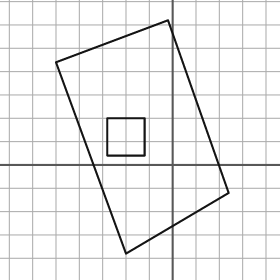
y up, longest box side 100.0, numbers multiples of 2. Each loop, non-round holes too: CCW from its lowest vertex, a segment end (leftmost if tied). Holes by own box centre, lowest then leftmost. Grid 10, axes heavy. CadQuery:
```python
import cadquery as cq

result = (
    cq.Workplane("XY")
    .moveTo(-20.0, -38.0)
    .lineTo(24.0, -12.0)
    .lineTo(-2.0, 62.0)
    .lineTo(-50.0, 44.0)
    .close()
    .moveTo(-28.0, 4.0)
    .lineTo(-12.0, 4.0)
    .lineTo(-12.0, 20.0)
    .lineTo(-28.0, 20.0)
    .close()
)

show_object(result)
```